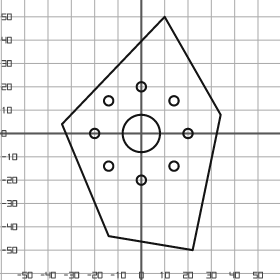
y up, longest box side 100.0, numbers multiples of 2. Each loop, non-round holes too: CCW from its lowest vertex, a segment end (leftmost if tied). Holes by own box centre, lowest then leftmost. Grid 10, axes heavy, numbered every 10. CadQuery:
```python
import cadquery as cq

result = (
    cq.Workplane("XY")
    .moveTo(22.0, -50.0)
    .lineTo(34.0, 8.0)
    .lineTo(10.0, 50.0)
    .lineTo(-34.0, 4.0)
    .lineTo(-14.0, -44.0)
    .close()
    .moveTo(0.0, -20.0)
    .circle(2.0)
    .moveTo(-14.0, -14.0)
    .circle(2.0)
    .moveTo(14.0, -14.0)
    .circle(2.0)
    .moveTo(-20.0, 0.0)
    .circle(2.0)
    .moveTo(0.0, 0.0)
    .circle(8.0)
    .moveTo(20.0, 0.0)
    .circle(2.0)
    .moveTo(-14.0, 14.0)
    .circle(2.0)
    .moveTo(14.0, 14.0)
    .circle(2.0)
    .moveTo(0.0, 20.0)
    .circle(2.0)
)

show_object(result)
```